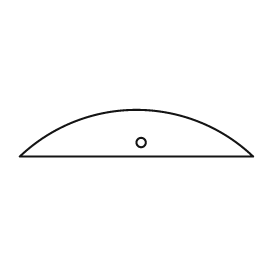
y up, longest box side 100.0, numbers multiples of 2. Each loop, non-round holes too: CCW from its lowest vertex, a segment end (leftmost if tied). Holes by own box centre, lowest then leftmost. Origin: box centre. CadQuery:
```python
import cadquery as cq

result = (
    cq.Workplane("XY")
    .moveTo(-50.0, -10.0)
    .lineTo(50.0, -10.0)
    .threePointArc((0.0, 10.0), (-50.0, -10.0))
    .close()
    .moveTo(2.0, -4.0)
    .circle(2.0)
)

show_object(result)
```